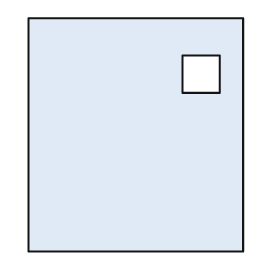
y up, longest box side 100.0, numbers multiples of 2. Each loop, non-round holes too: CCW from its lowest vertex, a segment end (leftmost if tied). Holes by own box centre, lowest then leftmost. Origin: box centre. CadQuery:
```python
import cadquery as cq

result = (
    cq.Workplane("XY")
    .moveTo(-46.0, -50.0)
    .lineTo(46.0, -50.0)
    .lineTo(46.0, 50.0)
    .lineTo(-46.0, 50.0)
    .close()
    .moveTo(20.0, 18.0)
    .lineTo(36.0, 18.0)
    .lineTo(36.0, 34.0)
    .lineTo(20.0, 34.0)
    .close()
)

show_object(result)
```